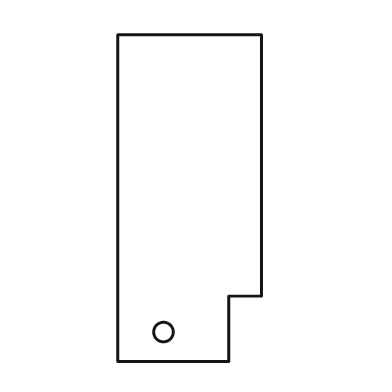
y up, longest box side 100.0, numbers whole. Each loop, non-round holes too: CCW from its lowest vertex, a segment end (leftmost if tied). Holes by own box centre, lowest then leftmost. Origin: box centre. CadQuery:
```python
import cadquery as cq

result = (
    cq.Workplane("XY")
    .moveTo(-22.0, -50.0)
    .lineTo(12.0, -50.0)
    .lineTo(12.0, -30.0)
    .lineTo(22.0, -30.0)
    .lineTo(22.0, 50.0)
    .lineTo(-22.0, 50.0)
    .close()
    .moveTo(-8.0, -41.0)
    .circle(3.0)
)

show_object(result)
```